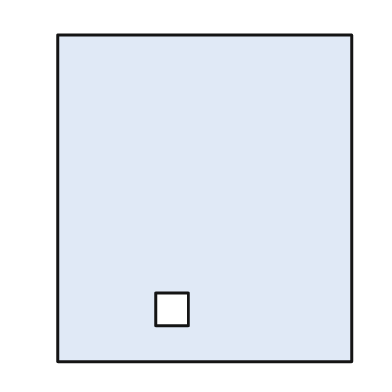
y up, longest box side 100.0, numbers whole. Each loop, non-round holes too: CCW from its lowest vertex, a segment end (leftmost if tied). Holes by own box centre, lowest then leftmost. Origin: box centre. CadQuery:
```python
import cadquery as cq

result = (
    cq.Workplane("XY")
    .moveTo(-45.0, -50.0)
    .lineTo(45.0, -50.0)
    .lineTo(45.0, 50.0)
    .lineTo(-45.0, 50.0)
    .close()
    .moveTo(-15.0, -39.0)
    .lineTo(-5.0, -39.0)
    .lineTo(-5.0, -29.0)
    .lineTo(-15.0, -29.0)
    .close()
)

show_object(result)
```